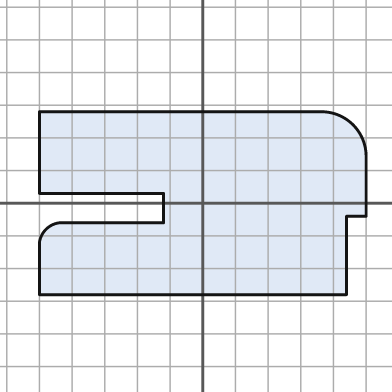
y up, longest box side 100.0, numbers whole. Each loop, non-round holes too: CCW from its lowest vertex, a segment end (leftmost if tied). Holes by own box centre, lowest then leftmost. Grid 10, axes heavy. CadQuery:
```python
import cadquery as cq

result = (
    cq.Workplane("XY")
    .moveTo(-50.0, -28.0)
    .lineTo(44.0, -28.0)
    .lineTo(44.0, -4.0)
    .lineTo(50.0, -4.0)
    .lineTo(50.0, 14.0)
    .threePointArc((46.0, 24.0), (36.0, 28.0))
    .lineTo(-50.0, 28.0)
    .lineTo(-50.0, 3.0)
    .lineTo(-12.0, 3.0)
    .lineTo(-12.0, -6.0)
    .lineTo(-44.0, -6.0)
    .threePointArc((-48.0, -8.0), (-50.0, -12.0))
    .close()
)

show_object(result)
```